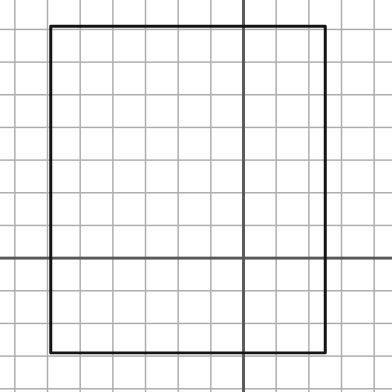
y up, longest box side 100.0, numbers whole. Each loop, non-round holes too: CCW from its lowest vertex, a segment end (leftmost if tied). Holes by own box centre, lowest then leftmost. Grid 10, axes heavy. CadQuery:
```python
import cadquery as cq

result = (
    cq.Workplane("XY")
    .moveTo(-59.0, -29.0)
    .lineTo(25.0, -29.0)
    .lineTo(25.0, 71.0)
    .lineTo(-59.0, 71.0)
    .close()
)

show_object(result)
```